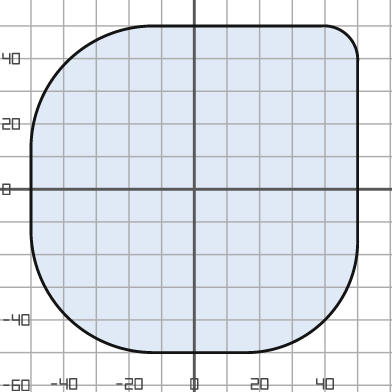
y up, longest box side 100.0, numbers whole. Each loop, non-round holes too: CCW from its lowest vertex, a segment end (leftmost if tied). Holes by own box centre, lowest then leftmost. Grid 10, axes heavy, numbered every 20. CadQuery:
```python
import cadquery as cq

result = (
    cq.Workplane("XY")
    .moveTo(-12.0, -50.0)
    .lineTo(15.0, -50.0)
    .threePointArc((40.0, -40.0), (50.0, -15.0))
    .lineTo(50.0, 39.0)
    .threePointArc((47.0, 47.0), (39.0, 50.0))
    .lineTo(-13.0, 50.0)
    .threePointArc((-39.0, 39.0), (-50.0, 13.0))
    .lineTo(-50.0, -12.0)
    .threePointArc((-39.0, -39.0), (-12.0, -50.0))
    .close()
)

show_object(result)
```